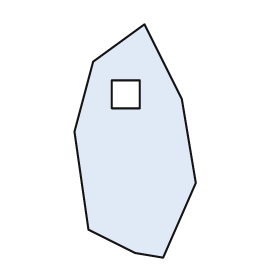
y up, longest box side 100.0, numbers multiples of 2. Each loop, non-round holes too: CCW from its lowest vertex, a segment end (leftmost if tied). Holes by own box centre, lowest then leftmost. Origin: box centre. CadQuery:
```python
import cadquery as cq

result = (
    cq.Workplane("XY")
    .moveTo(12.0, -50.0)
    .lineTo(26.0, -18.0)
    .lineTo(20.0, 18.0)
    .lineTo(4.0, 50.0)
    .lineTo(-18.0, 34.0)
    .lineTo(-26.0, 4.0)
    .lineTo(-20.0, -38.0)
    .lineTo(0.0, -48.0)
    .close()
    .moveTo(-10.0, 14.0)
    .lineTo(2.0, 14.0)
    .lineTo(2.0, 26.0)
    .lineTo(-10.0, 26.0)
    .close()
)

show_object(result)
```